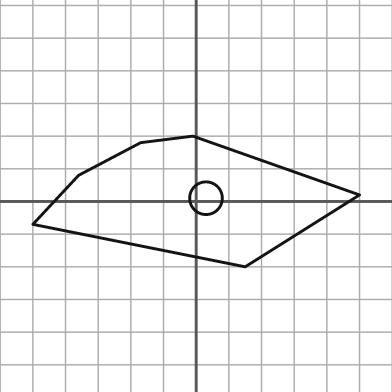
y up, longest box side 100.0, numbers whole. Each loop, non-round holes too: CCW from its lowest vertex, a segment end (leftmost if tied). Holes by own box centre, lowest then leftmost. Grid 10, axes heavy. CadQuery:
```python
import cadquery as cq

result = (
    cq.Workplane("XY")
    .moveTo(15.0, -20.0)
    .lineTo(50.0, 2.0)
    .lineTo(-1.0, 20.0)
    .lineTo(-17.0, 18.0)
    .lineTo(-36.0, 8.0)
    .lineTo(-50.0, -7.0)
    .close()
    .moveTo(3.0, 1.0)
    .circle(5.0)
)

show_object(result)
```